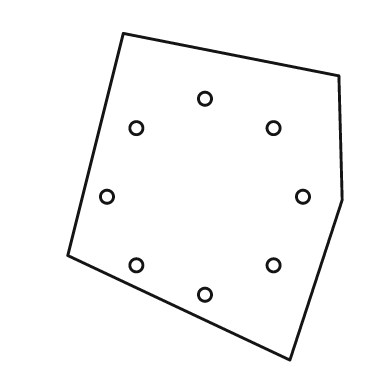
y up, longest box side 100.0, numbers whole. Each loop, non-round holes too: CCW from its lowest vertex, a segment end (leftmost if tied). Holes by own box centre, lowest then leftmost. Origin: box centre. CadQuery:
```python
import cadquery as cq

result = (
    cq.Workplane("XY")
    .moveTo(26.0, -50.0)
    .lineTo(42.0, -1.0)
    .lineTo(41.0, 37.0)
    .lineTo(-25.0, 50.0)
    .lineTo(-42.0, -18.0)
    .close()
    .moveTo(0.0, -30.0)
    .circle(2.0)
    .moveTo(-21.0, -21.0)
    .circle(2.0)
    .moveTo(21.0, -21.0)
    .circle(2.0)
    .moveTo(-30.0, 0.0)
    .circle(2.0)
    .moveTo(30.0, 0.0)
    .circle(2.0)
    .moveTo(-21.0, 21.0)
    .circle(2.0)
    .moveTo(21.0, 21.0)
    .circle(2.0)
    .moveTo(0.0, 30.0)
    .circle(2.0)
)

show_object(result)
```